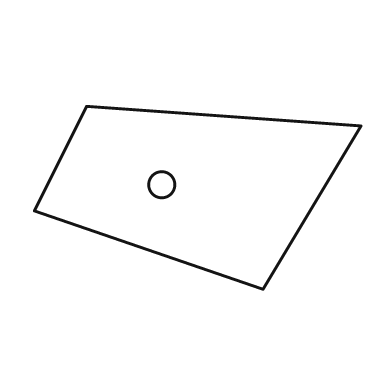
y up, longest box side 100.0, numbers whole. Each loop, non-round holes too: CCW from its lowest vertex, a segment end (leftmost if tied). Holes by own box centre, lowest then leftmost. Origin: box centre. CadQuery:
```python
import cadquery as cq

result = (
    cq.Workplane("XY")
    .moveTo(20.0, -28.0)
    .lineTo(50.0, 22.0)
    .lineTo(-34.0, 28.0)
    .lineTo(-50.0, -4.0)
    .close()
    .moveTo(-11.0, 4.0)
    .circle(4.0)
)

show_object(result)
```